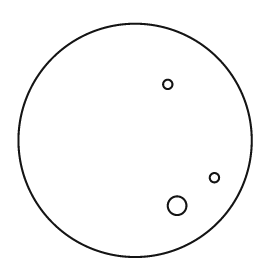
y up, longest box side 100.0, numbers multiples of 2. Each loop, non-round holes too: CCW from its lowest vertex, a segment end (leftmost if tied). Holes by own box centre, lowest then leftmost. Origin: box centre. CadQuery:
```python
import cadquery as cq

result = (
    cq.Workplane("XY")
    .moveTo(0.0, 0.0)
    .circle(50.0)
    .moveTo(18.0, -28.0)
    .circle(4.0)
    .moveTo(34.0, -16.0)
    .circle(2.0)
    .moveTo(14.0, 24.0)
    .circle(2.0)
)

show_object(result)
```